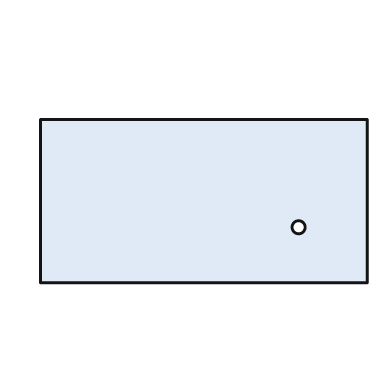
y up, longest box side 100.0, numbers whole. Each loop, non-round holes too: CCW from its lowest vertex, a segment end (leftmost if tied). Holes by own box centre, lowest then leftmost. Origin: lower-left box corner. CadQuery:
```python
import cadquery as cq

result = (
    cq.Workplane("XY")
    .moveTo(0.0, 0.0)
    .lineTo(100.0, 0.0)
    .lineTo(100.0, 50.0)
    .lineTo(0.0, 50.0)
    .close()
    .moveTo(79.0, 17.0)
    .circle(2.0)
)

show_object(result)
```